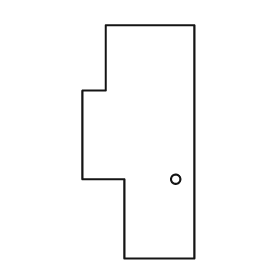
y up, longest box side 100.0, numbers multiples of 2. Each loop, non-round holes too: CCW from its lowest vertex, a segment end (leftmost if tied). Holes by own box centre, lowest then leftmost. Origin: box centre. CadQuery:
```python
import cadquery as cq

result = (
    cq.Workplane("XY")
    .moveTo(-6.0, -50.0)
    .lineTo(24.0, -50.0)
    .lineTo(24.0, 50.0)
    .lineTo(-14.0, 50.0)
    .lineTo(-14.0, 22.0)
    .lineTo(-24.0, 22.0)
    .lineTo(-24.0, -16.0)
    .lineTo(-6.0, -16.0)
    .close()
    .moveTo(16.0, -16.0)
    .circle(2.0)
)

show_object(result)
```